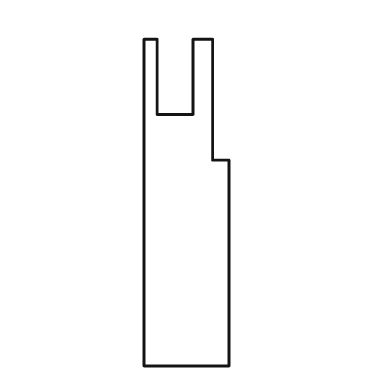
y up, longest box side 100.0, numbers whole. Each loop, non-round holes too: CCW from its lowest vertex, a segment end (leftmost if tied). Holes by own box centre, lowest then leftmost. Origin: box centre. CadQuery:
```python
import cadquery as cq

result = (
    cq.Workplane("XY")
    .moveTo(-13.0, -50.0)
    .lineTo(13.0, -50.0)
    .lineTo(13.0, 13.0)
    .lineTo(8.0, 13.0)
    .lineTo(8.0, 50.0)
    .lineTo(2.0, 50.0)
    .lineTo(2.0, 27.0)
    .lineTo(-9.0, 27.0)
    .lineTo(-9.0, 50.0)
    .lineTo(-13.0, 50.0)
    .close()
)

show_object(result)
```